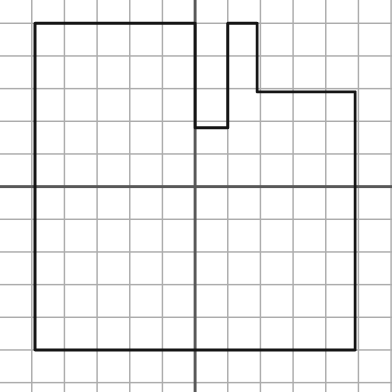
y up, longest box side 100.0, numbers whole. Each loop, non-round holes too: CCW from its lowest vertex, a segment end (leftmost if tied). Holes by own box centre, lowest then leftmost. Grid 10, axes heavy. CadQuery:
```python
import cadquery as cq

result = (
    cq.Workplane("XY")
    .moveTo(-49.0, -50.0)
    .lineTo(49.0, -50.0)
    .lineTo(49.0, 29.0)
    .lineTo(19.0, 29.0)
    .lineTo(19.0, 50.0)
    .lineTo(10.0, 50.0)
    .lineTo(10.0, 18.0)
    .lineTo(0.0, 18.0)
    .lineTo(0.0, 50.0)
    .lineTo(-49.0, 50.0)
    .close()
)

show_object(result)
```